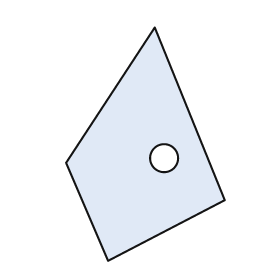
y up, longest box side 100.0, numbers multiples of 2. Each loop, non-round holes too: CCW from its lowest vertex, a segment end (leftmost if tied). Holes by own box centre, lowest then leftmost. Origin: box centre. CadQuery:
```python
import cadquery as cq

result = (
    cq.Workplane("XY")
    .moveTo(-16.0, -50.0)
    .lineTo(34.0, -24.0)
    .lineTo(4.0, 50.0)
    .lineTo(-34.0, -8.0)
    .close()
    .moveTo(8.0, -6.0)
    .circle(6.0)
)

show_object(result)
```